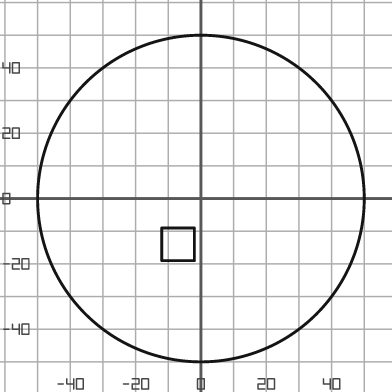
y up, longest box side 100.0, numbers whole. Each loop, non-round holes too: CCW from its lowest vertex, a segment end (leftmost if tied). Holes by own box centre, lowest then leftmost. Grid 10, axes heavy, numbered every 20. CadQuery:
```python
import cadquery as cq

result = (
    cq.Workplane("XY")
    .moveTo(0.0, 0.0)
    .circle(50.0)
    .moveTo(-12.0, -19.0)
    .lineTo(-2.0, -19.0)
    .lineTo(-2.0, -9.0)
    .lineTo(-12.0, -9.0)
    .close()
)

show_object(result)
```